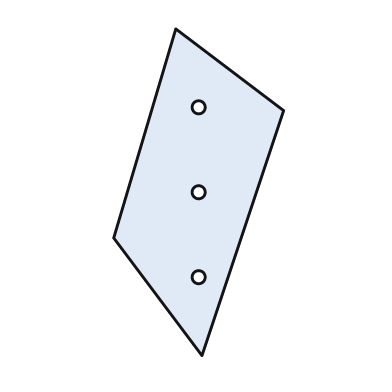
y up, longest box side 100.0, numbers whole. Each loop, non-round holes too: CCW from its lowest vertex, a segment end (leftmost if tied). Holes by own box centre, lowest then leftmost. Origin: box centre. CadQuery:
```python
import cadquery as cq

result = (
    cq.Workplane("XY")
    .moveTo(1.0, -50.0)
    .lineTo(26.0, 25.0)
    .lineTo(-7.0, 50.0)
    .lineTo(-26.0, -14.0)
    .close()
    .moveTo(0.0, -26.0)
    .circle(2.0)
    .moveTo(0.0, 0.0)
    .circle(2.0)
    .moveTo(0.0, 26.0)
    .circle(2.0)
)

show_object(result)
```